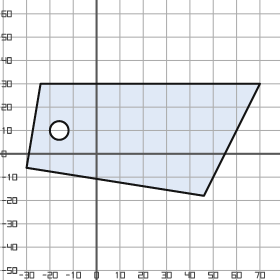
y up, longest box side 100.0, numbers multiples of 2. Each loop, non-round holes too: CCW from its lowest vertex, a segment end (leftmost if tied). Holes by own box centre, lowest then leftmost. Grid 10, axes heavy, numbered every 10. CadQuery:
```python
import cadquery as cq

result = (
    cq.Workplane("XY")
    .moveTo(46.0, -18.0)
    .lineTo(70.0, 30.0)
    .lineTo(-24.0, 30.0)
    .lineTo(-30.0, -6.0)
    .close()
    .moveTo(-16.0, 10.0)
    .circle(4.0)
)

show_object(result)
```